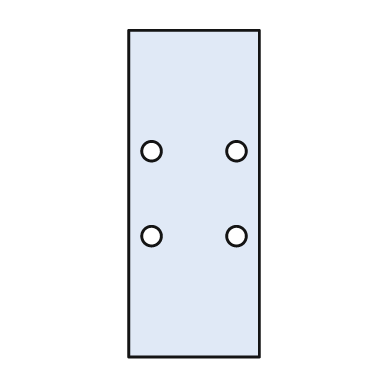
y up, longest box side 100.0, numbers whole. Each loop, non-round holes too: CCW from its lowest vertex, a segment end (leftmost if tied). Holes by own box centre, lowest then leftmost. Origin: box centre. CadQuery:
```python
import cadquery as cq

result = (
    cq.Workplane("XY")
    .moveTo(-20.0, -50.0)
    .lineTo(20.0, -50.0)
    .lineTo(20.0, 50.0)
    .lineTo(-20.0, 50.0)
    .close()
    .moveTo(-13.0, -13.0)
    .circle(3.0)
    .moveTo(13.0, -13.0)
    .circle(3.0)
    .moveTo(-13.0, 13.0)
    .circle(3.0)
    .moveTo(13.0, 13.0)
    .circle(3.0)
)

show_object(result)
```